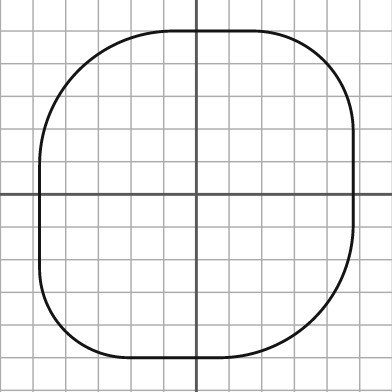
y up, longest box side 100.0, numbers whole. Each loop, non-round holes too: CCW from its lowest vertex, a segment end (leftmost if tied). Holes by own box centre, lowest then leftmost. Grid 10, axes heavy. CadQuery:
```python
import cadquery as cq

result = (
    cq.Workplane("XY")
    .moveTo(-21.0, -50.0)
    .lineTo(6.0, -50.0)
    .threePointArc((36.0, -38.0), (48.0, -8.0))
    .lineTo(48.0, 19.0)
    .threePointArc((39.0, 41.0), (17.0, 50.0))
    .lineTo(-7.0, 50.0)
    .threePointArc((-36.0, 38.0), (-48.0, 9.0))
    .lineTo(-48.0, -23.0)
    .threePointArc((-40.0, -42.0), (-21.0, -50.0))
    .close()
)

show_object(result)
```